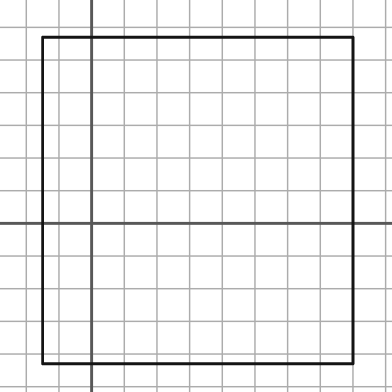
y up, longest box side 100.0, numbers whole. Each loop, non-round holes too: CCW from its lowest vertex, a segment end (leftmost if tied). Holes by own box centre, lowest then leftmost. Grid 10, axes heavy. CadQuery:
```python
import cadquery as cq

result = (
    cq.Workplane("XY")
    .moveTo(-15.0, -43.0)
    .lineTo(80.0, -43.0)
    .lineTo(80.0, 57.0)
    .lineTo(-15.0, 57.0)
    .close()
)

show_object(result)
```